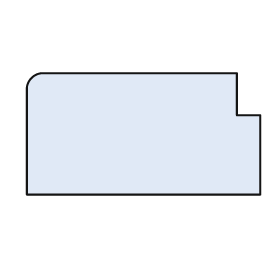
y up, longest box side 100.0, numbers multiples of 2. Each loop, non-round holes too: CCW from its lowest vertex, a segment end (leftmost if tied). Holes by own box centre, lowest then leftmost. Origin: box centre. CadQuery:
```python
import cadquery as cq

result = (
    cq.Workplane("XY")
    .moveTo(-50.0, -26.0)
    .lineTo(50.0, -26.0)
    .lineTo(50.0, 8.0)
    .lineTo(40.0, 8.0)
    .lineTo(40.0, 26.0)
    .lineTo(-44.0, 26.0)
    .threePointArc((-48.0, 24.0), (-50.0, 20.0))
    .close()
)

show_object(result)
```